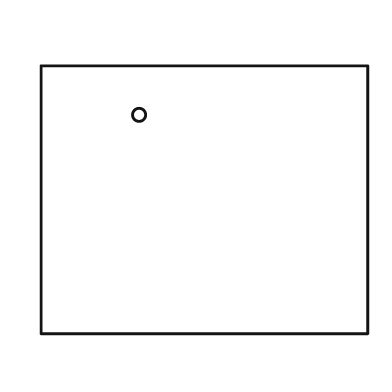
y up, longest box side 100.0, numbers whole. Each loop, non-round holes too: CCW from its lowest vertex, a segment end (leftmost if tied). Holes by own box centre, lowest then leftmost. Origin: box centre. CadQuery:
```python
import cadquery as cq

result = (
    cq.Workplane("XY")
    .moveTo(-50.0, -41.0)
    .lineTo(50.0, -41.0)
    .lineTo(50.0, 41.0)
    .lineTo(-50.0, 41.0)
    .close()
    .moveTo(-20.0, 26.0)
    .circle(2.0)
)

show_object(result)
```